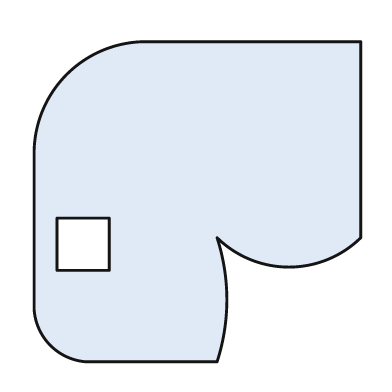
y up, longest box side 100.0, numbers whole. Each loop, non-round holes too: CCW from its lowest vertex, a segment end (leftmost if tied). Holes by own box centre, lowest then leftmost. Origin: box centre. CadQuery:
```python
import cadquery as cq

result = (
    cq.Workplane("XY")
    .moveTo(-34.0, -49.0)
    .lineTo(6.0, -49.0)
    .threePointArc((9.0, -30.0), (6.0, -11.0))
    .threePointArc((28.0, -20.0), (50.0, -11.0))
    .lineTo(50.0, 49.0)
    .lineTo(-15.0, 49.0)
    .threePointArc((-40.0, 39.0), (-50.0, 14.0))
    .lineTo(-50.0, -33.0)
    .threePointArc((-45.0, -44.0), (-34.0, -49.0))
    .close()
    .moveTo(-43.0, -21.0)
    .lineTo(-27.0, -21.0)
    .lineTo(-27.0, -5.0)
    .lineTo(-43.0, -5.0)
    .close()
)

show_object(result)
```